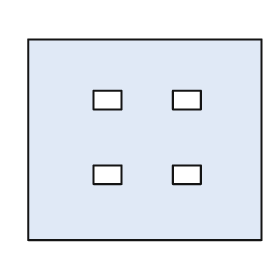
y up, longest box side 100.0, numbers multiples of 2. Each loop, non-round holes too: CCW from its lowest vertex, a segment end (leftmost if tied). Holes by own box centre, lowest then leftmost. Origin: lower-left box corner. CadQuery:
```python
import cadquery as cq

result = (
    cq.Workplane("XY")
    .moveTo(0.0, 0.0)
    .lineTo(100.0, 0.0)
    .lineTo(100.0, 86.0)
    .lineTo(0.0, 86.0)
    .close()
    .moveTo(28.0, 24.0)
    .lineTo(40.0, 24.0)
    .lineTo(40.0, 32.0)
    .lineTo(28.0, 32.0)
    .close()
    .moveTo(62.0, 24.0)
    .lineTo(74.0, 24.0)
    .lineTo(74.0, 32.0)
    .lineTo(62.0, 32.0)
    .close()
    .moveTo(28.0, 56.0)
    .lineTo(40.0, 56.0)
    .lineTo(40.0, 64.0)
    .lineTo(28.0, 64.0)
    .close()
    .moveTo(62.0, 56.0)
    .lineTo(74.0, 56.0)
    .lineTo(74.0, 64.0)
    .lineTo(62.0, 64.0)
    .close()
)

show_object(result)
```